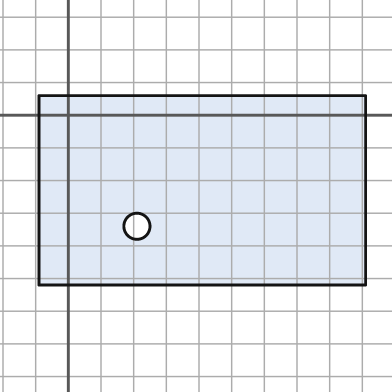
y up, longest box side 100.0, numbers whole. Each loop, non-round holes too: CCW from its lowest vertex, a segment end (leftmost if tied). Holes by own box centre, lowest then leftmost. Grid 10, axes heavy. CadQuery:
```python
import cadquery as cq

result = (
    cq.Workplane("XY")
    .moveTo(-9.0, -52.0)
    .lineTo(91.0, -52.0)
    .lineTo(91.0, 6.0)
    .lineTo(-9.0, 6.0)
    .close()
    .moveTo(21.0, -34.0)
    .circle(4.0)
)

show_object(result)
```